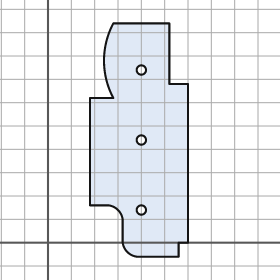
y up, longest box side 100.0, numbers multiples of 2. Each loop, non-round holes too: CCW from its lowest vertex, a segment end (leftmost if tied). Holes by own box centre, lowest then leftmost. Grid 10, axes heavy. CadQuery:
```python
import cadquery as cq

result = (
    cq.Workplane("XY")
    .moveTo(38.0, -6.0)
    .lineTo(56.0, -6.0)
    .lineTo(56.0, 0.0)
    .lineTo(60.0, 0.0)
    .lineTo(60.0, 68.0)
    .lineTo(52.0, 68.0)
    .lineTo(52.0, 94.0)
    .lineTo(28.0, 94.0)
    .threePointArc((24.0, 78.0), (28.0, 62.0))
    .lineTo(18.0, 62.0)
    .lineTo(18.0, 16.0)
    .lineTo(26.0, 16.0)
    .threePointArc((30.0, 14.0), (32.0, 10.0))
    .lineTo(32.0, 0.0)
    .threePointArc((34.0, -4.0), (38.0, -6.0))
    .close()
    .moveTo(40.0, 14.0)
    .circle(2.0)
    .moveTo(40.0, 44.0)
    .circle(2.0)
    .moveTo(40.0, 74.0)
    .circle(2.0)
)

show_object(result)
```